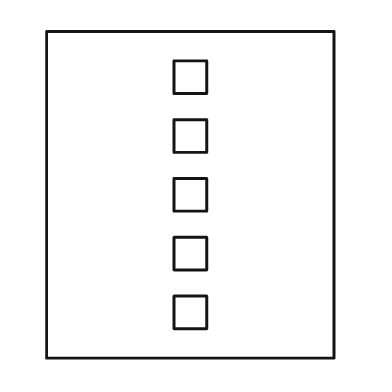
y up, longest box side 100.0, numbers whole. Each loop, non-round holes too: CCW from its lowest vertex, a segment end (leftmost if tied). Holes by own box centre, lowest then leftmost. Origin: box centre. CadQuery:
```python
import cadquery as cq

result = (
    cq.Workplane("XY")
    .moveTo(-44.0, -50.0)
    .lineTo(44.0, -50.0)
    .lineTo(44.0, 50.0)
    .lineTo(-44.0, 50.0)
    .close()
    .moveTo(-5.0, -41.0)
    .lineTo(5.0, -41.0)
    .lineTo(5.0, -31.0)
    .lineTo(-5.0, -31.0)
    .close()
    .moveTo(-5.0, -23.0)
    .lineTo(5.0, -23.0)
    .lineTo(5.0, -13.0)
    .lineTo(-5.0, -13.0)
    .close()
    .moveTo(-5.0, -5.0)
    .lineTo(5.0, -5.0)
    .lineTo(5.0, 5.0)
    .lineTo(-5.0, 5.0)
    .close()
    .moveTo(-5.0, 13.0)
    .lineTo(5.0, 13.0)
    .lineTo(5.0, 23.0)
    .lineTo(-5.0, 23.0)
    .close()
    .moveTo(-5.0, 31.0)
    .lineTo(5.0, 31.0)
    .lineTo(5.0, 41.0)
    .lineTo(-5.0, 41.0)
    .close()
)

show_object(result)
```